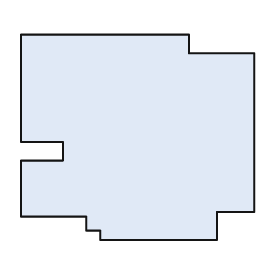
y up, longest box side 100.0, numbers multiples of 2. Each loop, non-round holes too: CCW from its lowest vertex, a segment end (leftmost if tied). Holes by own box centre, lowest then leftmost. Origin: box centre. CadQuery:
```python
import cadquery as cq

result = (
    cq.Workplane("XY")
    .moveTo(-16.0, -44.0)
    .lineTo(34.0, -44.0)
    .lineTo(34.0, -32.0)
    .lineTo(50.0, -32.0)
    .lineTo(50.0, 36.0)
    .lineTo(22.0, 36.0)
    .lineTo(22.0, 44.0)
    .lineTo(-50.0, 44.0)
    .lineTo(-50.0, -2.0)
    .lineTo(-32.0, -2.0)
    .lineTo(-32.0, -10.0)
    .lineTo(-50.0, -10.0)
    .lineTo(-50.0, -34.0)
    .lineTo(-22.0, -34.0)
    .lineTo(-22.0, -40.0)
    .lineTo(-16.0, -40.0)
    .close()
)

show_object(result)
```